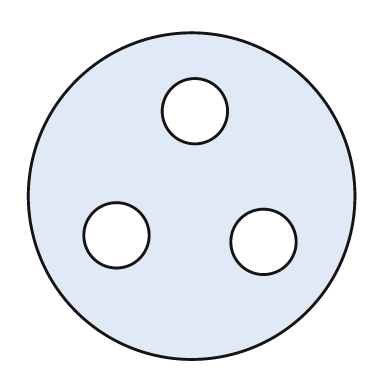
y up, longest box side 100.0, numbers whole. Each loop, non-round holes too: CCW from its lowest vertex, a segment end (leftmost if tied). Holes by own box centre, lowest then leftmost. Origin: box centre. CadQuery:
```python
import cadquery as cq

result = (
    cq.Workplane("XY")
    .moveTo(0.0, 0.0)
    .circle(50.0)
    .moveTo(22.0, -14.0)
    .circle(10.0)
    .moveTo(-23.0, -12.0)
    .circle(10.0)
    .moveTo(1.0, 26.0)
    .circle(10.0)
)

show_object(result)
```